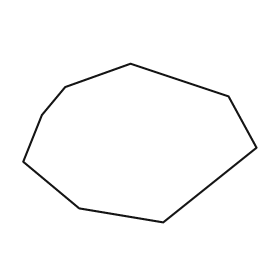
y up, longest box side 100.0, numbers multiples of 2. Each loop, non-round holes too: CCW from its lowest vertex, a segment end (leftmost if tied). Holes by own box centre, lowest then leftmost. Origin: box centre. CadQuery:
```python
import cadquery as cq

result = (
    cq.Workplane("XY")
    .moveTo(10.0, -34.0)
    .lineTo(50.0, -2.0)
    .lineTo(38.0, 20.0)
    .lineTo(-4.0, 34.0)
    .lineTo(-32.0, 24.0)
    .lineTo(-42.0, 12.0)
    .lineTo(-50.0, -8.0)
    .lineTo(-26.0, -28.0)
    .close()
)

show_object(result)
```